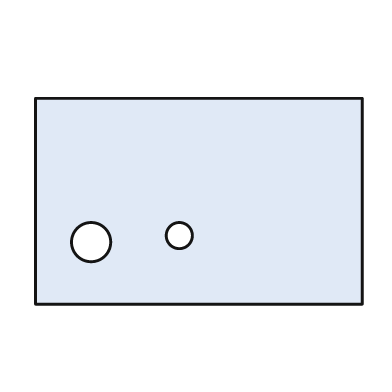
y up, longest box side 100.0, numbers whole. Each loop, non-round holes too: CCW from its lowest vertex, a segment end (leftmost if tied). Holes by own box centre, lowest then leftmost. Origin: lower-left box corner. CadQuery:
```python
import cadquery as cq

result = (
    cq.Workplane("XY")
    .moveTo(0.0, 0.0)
    .lineTo(100.0, 0.0)
    .lineTo(100.0, 63.0)
    .lineTo(0.0, 63.0)
    .close()
    .moveTo(17.0, 19.0)
    .circle(6.0)
    .moveTo(44.0, 21.0)
    .circle(4.0)
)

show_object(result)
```